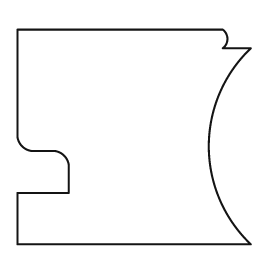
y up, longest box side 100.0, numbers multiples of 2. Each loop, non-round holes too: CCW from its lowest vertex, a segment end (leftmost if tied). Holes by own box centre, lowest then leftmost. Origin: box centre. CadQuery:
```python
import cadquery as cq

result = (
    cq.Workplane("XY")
    .moveTo(-50.0, -46.0)
    .lineTo(50.0, -46.0)
    .threePointArc((32.0, -4.0), (50.0, 38.0))
    .lineTo(38.0, 38.0)
    .threePointArc((40.0, 42.0), (38.0, 46.0))
    .lineTo(-50.0, 46.0)
    .lineTo(-50.0, 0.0)
    .threePointArc((-48.0, -4.0), (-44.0, -6.0))
    .lineTo(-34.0, -6.0)
    .threePointArc((-30.0, -8.0), (-28.0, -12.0))
    .lineTo(-28.0, -24.0)
    .lineTo(-50.0, -24.0)
    .close()
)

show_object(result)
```